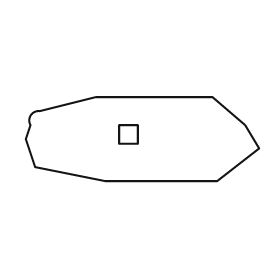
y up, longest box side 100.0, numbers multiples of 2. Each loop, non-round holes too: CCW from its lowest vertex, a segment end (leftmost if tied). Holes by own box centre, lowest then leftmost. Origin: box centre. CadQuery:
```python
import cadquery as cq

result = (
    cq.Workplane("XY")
    .moveTo(-16.0, -18.0)
    .lineTo(32.0, -18.0)
    .lineTo(50.0, -4.0)
    .lineTo(44.0, 6.0)
    .lineTo(30.0, 18.0)
    .lineTo(-20.0, 18.0)
    .lineTo(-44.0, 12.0)
    .threePointArc((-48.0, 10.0), (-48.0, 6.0))
    .lineTo(-50.0, 0.0)
    .lineTo(-46.0, -12.0)
    .close()
    .moveTo(-10.0, -2.0)
    .lineTo(-2.0, -2.0)
    .lineTo(-2.0, 6.0)
    .lineTo(-10.0, 6.0)
    .close()
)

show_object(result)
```